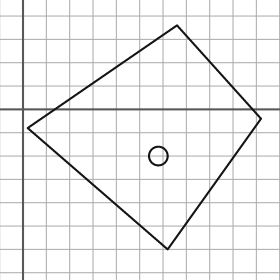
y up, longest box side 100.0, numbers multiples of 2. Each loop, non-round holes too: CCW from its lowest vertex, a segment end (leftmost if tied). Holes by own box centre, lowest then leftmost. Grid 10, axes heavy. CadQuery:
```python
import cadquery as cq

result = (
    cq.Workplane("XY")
    .moveTo(62.0, -60.0)
    .lineTo(102.0, -4.0)
    .lineTo(66.0, 36.0)
    .lineTo(2.0, -8.0)
    .close()
    .moveTo(58.0, -20.0)
    .circle(4.0)
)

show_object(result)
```